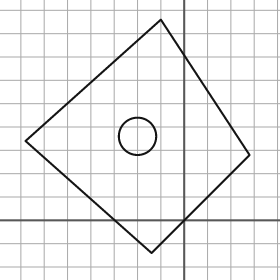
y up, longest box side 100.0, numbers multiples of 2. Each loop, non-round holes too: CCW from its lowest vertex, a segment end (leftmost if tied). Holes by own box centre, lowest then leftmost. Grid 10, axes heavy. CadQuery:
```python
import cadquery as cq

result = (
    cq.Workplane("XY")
    .moveTo(-14.0, -14.0)
    .lineTo(28.0, 28.0)
    .lineTo(-10.0, 86.0)
    .lineTo(-68.0, 34.0)
    .close()
    .moveTo(-20.0, 36.0)
    .circle(8.0)
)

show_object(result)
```